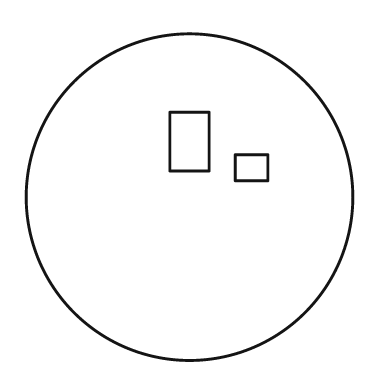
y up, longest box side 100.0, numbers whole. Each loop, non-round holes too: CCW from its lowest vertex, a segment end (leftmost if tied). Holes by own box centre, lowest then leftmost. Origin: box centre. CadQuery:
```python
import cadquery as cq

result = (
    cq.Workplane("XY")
    .moveTo(0.0, 0.0)
    .circle(50.0)
    .moveTo(14.0, 5.0)
    .lineTo(24.0, 5.0)
    .lineTo(24.0, 13.0)
    .lineTo(14.0, 13.0)
    .close()
    .moveTo(-6.0, 8.0)
    .lineTo(6.0, 8.0)
    .lineTo(6.0, 26.0)
    .lineTo(-6.0, 26.0)
    .close()
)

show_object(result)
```